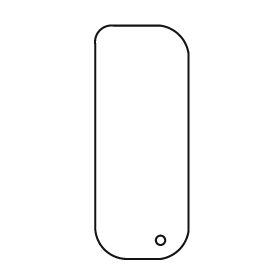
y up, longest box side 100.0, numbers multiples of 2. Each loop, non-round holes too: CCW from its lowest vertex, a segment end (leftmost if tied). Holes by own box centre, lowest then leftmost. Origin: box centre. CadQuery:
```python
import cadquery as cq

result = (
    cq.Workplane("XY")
    .moveTo(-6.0, -50.0)
    .lineTo(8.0, -50.0)
    .threePointArc((16.0, -46.0), (20.0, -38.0))
    .lineTo(20.0, 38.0)
    .threePointArc((16.0, 46.0), (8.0, 50.0))
    .lineTo(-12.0, 50.0)
    .threePointArc((-18.0, 48.0), (-20.0, 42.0))
    .lineTo(-20.0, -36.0)
    .threePointArc((-16.0, -46.0), (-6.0, -50.0))
    .close()
    .moveTo(8.0, -42.0)
    .circle(2.0)
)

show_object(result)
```